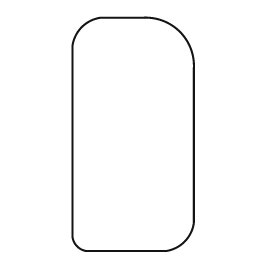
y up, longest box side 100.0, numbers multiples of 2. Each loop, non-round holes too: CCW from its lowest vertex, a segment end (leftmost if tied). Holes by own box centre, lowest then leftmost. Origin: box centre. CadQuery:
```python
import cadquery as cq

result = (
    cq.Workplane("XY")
    .moveTo(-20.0, -50.0)
    .lineTo(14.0, -50.0)
    .threePointArc((22.0, -46.0), (26.0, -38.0))
    .lineTo(26.0, 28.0)
    .threePointArc((20.0, 44.0), (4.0, 50.0))
    .lineTo(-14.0, 50.0)
    .threePointArc((-22.0, 46.0), (-26.0, 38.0))
    .lineTo(-26.0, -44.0)
    .threePointArc((-24.0, -48.0), (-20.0, -50.0))
    .close()
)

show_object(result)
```